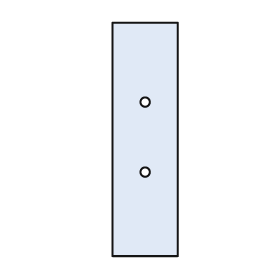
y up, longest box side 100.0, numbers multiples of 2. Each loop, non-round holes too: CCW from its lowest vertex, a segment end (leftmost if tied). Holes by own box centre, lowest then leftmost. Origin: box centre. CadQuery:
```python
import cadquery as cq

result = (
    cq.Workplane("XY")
    .moveTo(-14.0, -50.0)
    .lineTo(14.0, -50.0)
    .lineTo(14.0, 50.0)
    .lineTo(-14.0, 50.0)
    .close()
    .moveTo(0.0, -14.0)
    .circle(2.0)
    .moveTo(0.0, 16.0)
    .circle(2.0)
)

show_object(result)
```